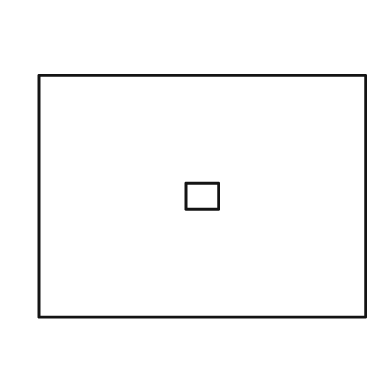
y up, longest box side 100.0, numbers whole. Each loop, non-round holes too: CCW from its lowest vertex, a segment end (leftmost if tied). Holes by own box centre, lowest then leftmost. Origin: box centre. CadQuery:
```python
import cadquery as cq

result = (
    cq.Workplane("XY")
    .moveTo(-50.0, -37.0)
    .lineTo(50.0, -37.0)
    .lineTo(50.0, 37.0)
    .lineTo(-50.0, 37.0)
    .close()
    .moveTo(-5.0, -4.0)
    .lineTo(5.0, -4.0)
    .lineTo(5.0, 4.0)
    .lineTo(-5.0, 4.0)
    .close()
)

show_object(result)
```